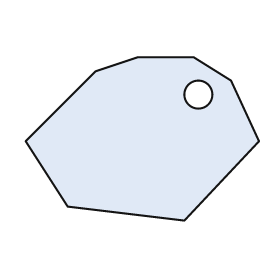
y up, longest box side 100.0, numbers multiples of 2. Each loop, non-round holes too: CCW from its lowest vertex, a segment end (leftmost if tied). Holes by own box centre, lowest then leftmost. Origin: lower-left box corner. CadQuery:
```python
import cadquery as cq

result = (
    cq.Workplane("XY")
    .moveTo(68.0, 0.0)
    .lineTo(100.0, 34.0)
    .lineTo(88.0, 60.0)
    .lineTo(72.0, 70.0)
    .lineTo(48.0, 70.0)
    .lineTo(30.0, 64.0)
    .lineTo(0.0, 34.0)
    .lineTo(18.0, 6.0)
    .close()
    .moveTo(74.0, 54.0)
    .circle(6.0)
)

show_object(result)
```